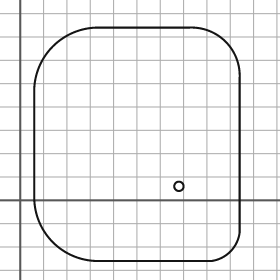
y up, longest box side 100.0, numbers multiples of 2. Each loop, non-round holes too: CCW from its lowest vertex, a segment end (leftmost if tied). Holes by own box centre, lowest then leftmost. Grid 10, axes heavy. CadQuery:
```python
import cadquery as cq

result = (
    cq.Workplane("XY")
    .moveTo(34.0, -26.0)
    .lineTo(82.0, -26.0)
    .threePointArc((90.0, -22.0), (94.0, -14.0))
    .lineTo(94.0, 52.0)
    .threePointArc((88.0, 68.0), (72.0, 74.0))
    .lineTo(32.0, 74.0)
    .threePointArc((14.0, 66.0), (6.0, 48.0))
    .lineTo(6.0, 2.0)
    .threePointArc((14.0, -18.0), (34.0, -26.0))
    .close()
    .moveTo(68.0, 6.0)
    .circle(2.0)
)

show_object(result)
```